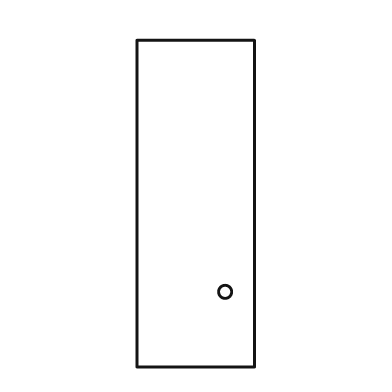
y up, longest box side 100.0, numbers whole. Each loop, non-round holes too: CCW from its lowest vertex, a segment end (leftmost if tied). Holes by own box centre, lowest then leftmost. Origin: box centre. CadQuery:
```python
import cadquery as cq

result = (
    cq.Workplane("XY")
    .moveTo(-18.0, -50.0)
    .lineTo(18.0, -50.0)
    .lineTo(18.0, 50.0)
    .lineTo(-18.0, 50.0)
    .close()
    .moveTo(9.0, -27.0)
    .circle(2.0)
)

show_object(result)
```